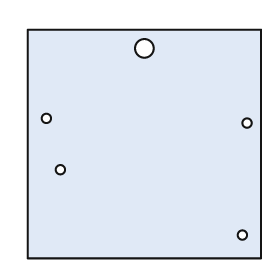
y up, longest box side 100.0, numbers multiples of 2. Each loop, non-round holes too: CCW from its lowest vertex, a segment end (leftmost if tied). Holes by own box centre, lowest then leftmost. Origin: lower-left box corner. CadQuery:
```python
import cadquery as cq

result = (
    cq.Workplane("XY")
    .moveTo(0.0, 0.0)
    .lineTo(100.0, 0.0)
    .lineTo(100.0, 98.0)
    .lineTo(0.0, 98.0)
    .close()
    .moveTo(92.0, 10.0)
    .circle(2.0)
    .moveTo(14.0, 38.0)
    .circle(2.0)
    .moveTo(94.0, 58.0)
    .circle(2.0)
    .moveTo(8.0, 60.0)
    .circle(2.0)
    .moveTo(50.0, 90.0)
    .circle(4.0)
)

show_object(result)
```